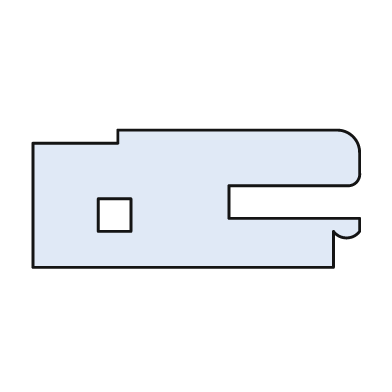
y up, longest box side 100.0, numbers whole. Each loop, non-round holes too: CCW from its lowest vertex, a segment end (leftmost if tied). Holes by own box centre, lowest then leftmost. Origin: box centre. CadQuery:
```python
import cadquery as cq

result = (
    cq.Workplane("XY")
    .moveTo(-50.0, -21.0)
    .lineTo(42.0, -21.0)
    .lineTo(42.0, -10.0)
    .threePointArc((46.0, -12.0), (50.0, -10.0))
    .lineTo(50.0, -6.0)
    .lineTo(10.0, -6.0)
    .lineTo(10.0, 4.0)
    .lineTo(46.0, 4.0)
    .threePointArc((49.0, 5.0), (50.0, 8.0))
    .lineTo(50.0, 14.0)
    .threePointArc((48.0, 19.0), (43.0, 21.0))
    .lineTo(-24.0, 21.0)
    .lineTo(-24.0, 17.0)
    .lineTo(-50.0, 17.0)
    .close()
    .moveTo(-30.0, -10.0)
    .lineTo(-20.0, -10.0)
    .lineTo(-20.0, 0.0)
    .lineTo(-30.0, 0.0)
    .close()
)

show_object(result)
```